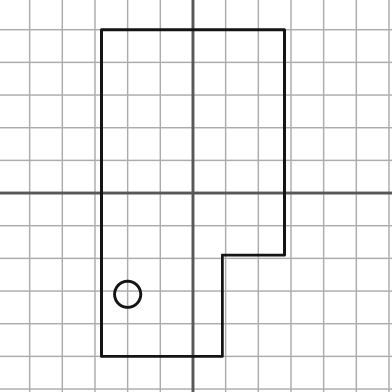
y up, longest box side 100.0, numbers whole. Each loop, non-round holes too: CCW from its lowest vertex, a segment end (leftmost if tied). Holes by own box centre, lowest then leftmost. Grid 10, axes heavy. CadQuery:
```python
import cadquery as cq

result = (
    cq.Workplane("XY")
    .moveTo(-28.0, -50.0)
    .lineTo(9.0, -50.0)
    .lineTo(9.0, -19.0)
    .lineTo(28.0, -19.0)
    .lineTo(28.0, 50.0)
    .lineTo(-28.0, 50.0)
    .close()
    .moveTo(-20.0, -31.0)
    .circle(4.0)
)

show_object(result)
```